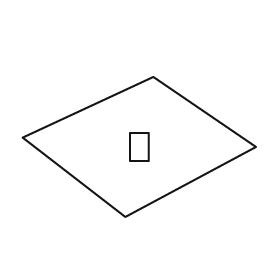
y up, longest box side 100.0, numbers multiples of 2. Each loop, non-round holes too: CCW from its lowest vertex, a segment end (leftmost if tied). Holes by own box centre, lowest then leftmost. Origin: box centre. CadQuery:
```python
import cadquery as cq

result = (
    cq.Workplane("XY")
    .moveTo(-6.0, -30.0)
    .lineTo(50.0, 0.0)
    .lineTo(6.0, 30.0)
    .lineTo(-50.0, 4.0)
    .close()
    .moveTo(-4.0, -6.0)
    .lineTo(4.0, -6.0)
    .lineTo(4.0, 6.0)
    .lineTo(-4.0, 6.0)
    .close()
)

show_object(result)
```